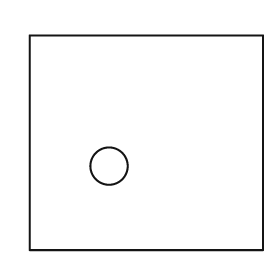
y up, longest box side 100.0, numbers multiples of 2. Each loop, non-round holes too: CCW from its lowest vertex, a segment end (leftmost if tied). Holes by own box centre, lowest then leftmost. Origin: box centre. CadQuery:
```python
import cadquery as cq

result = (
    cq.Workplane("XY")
    .moveTo(-50.0, -46.0)
    .lineTo(50.0, -46.0)
    .lineTo(50.0, 46.0)
    .lineTo(-50.0, 46.0)
    .close()
    .moveTo(-16.0, -10.0)
    .circle(8.0)
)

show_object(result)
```